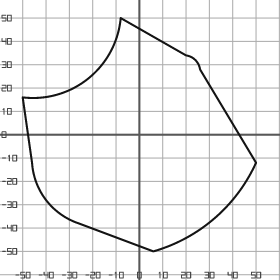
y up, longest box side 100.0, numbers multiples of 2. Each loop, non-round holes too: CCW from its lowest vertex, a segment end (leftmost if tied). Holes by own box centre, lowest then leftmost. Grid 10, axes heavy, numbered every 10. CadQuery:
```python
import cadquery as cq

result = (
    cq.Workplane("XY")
    .moveTo(6.0, -50.0)
    .threePointArc((32.0, -36.0), (50.0, -12.0))
    .lineTo(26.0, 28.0)
    .threePointArc((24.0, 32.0), (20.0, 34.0))
    .lineTo(-8.0, 50.0)
    .threePointArc((-22.0, 24.0), (-50.0, 16.0))
    .lineTo(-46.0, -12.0)
    .threePointArc((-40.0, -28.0), (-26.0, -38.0))
    .close()
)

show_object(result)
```